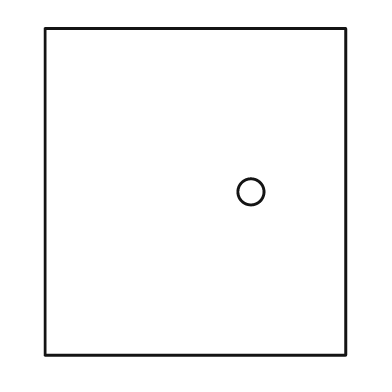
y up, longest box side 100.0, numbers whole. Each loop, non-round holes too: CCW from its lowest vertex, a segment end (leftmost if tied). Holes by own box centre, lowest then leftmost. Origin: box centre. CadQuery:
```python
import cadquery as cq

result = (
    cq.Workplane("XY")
    .moveTo(-46.0, -50.0)
    .lineTo(46.0, -50.0)
    .lineTo(46.0, 50.0)
    .lineTo(-46.0, 50.0)
    .close()
    .moveTo(17.0, 0.0)
    .circle(4.0)
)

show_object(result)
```